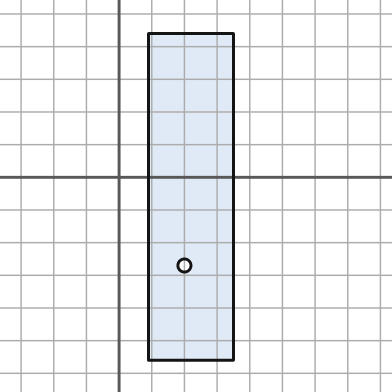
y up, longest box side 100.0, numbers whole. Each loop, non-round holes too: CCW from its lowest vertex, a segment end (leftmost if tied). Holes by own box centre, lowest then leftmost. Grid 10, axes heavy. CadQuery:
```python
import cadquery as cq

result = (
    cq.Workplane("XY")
    .moveTo(9.0, -56.0)
    .lineTo(35.0, -56.0)
    .lineTo(35.0, 44.0)
    .lineTo(9.0, 44.0)
    .close()
    .moveTo(20.0, -27.0)
    .circle(2.0)
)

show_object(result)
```